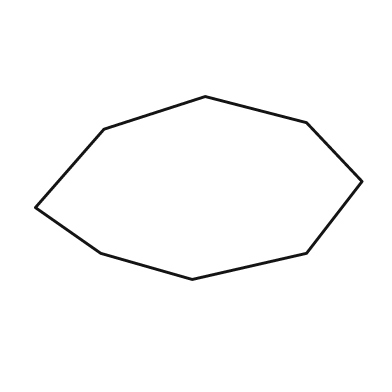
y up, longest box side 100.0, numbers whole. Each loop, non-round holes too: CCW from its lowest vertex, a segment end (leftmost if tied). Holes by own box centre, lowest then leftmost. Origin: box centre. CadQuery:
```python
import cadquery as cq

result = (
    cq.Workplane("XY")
    .moveTo(-2.0, -28.0)
    .lineTo(33.0, -20.0)
    .lineTo(50.0, 2.0)
    .lineTo(33.0, 20.0)
    .lineTo(2.0, 28.0)
    .lineTo(-29.0, 18.0)
    .lineTo(-50.0, -6.0)
    .lineTo(-30.0, -20.0)
    .close()
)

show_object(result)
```